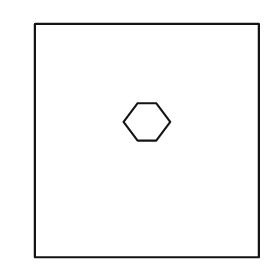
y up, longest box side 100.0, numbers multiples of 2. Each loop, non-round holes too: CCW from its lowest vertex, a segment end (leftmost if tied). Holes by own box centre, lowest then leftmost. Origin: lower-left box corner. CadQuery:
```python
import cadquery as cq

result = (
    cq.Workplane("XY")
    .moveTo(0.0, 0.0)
    .lineTo(96.0, 0.0)
    .lineTo(96.0, 100.0)
    .lineTo(0.0, 100.0)
    .close()
    .moveTo(44.0, 50.0)
    .lineTo(52.0, 50.0)
    .lineTo(58.0, 58.0)
    .lineTo(52.0, 66.0)
    .lineTo(44.0, 66.0)
    .lineTo(38.0, 58.0)
    .close()
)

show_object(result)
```